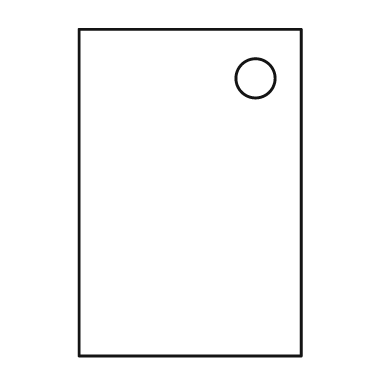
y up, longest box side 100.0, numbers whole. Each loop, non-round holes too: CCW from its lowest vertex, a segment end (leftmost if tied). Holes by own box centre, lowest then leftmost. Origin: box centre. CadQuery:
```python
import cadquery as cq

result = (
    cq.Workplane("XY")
    .moveTo(-34.0, -50.0)
    .lineTo(34.0, -50.0)
    .lineTo(34.0, 50.0)
    .lineTo(-34.0, 50.0)
    .close()
    .moveTo(20.0, 35.0)
    .circle(6.0)
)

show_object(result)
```